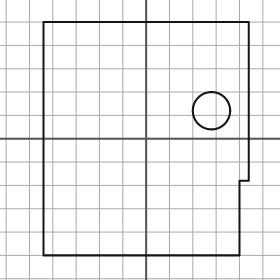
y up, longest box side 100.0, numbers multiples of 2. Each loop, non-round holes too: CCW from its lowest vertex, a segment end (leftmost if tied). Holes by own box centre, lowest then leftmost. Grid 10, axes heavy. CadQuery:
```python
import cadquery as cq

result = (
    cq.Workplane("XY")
    .moveTo(-44.0, -50.0)
    .lineTo(40.0, -50.0)
    .lineTo(40.0, -18.0)
    .lineTo(44.0, -18.0)
    .lineTo(44.0, 50.0)
    .lineTo(-44.0, 50.0)
    .close()
    .moveTo(28.0, 12.0)
    .circle(8.0)
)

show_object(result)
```